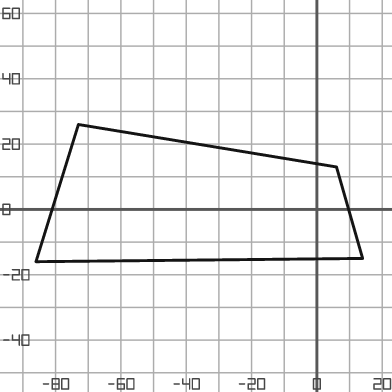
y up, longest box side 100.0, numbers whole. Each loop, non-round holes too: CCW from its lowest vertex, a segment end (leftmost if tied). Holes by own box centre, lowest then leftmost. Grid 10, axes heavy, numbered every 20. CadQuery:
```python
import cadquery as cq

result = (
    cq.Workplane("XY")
    .moveTo(-86.0, -16.0)
    .lineTo(14.0, -15.0)
    .lineTo(6.0, 13.0)
    .lineTo(-73.0, 26.0)
    .close()
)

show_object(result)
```